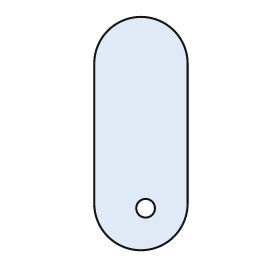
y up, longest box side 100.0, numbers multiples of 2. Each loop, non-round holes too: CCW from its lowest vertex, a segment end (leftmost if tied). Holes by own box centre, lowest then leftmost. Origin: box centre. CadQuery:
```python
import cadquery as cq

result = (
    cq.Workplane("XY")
    .moveTo(-20.0, -30.0)
    .threePointArc((0.0, -50.0), (20.0, -30.0))
    .lineTo(20.0, 30.0)
    .threePointArc((0.0, 50.0), (-20.0, 30.0))
    .close()
    .moveTo(2.0, -32.0)
    .circle(4.0)
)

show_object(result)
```